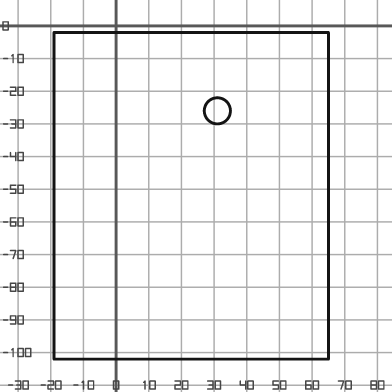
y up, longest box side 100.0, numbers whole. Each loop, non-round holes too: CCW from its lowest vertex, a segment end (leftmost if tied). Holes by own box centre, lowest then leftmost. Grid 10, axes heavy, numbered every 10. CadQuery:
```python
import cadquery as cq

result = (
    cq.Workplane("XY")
    .moveTo(-19.0, -102.0)
    .lineTo(65.0, -102.0)
    .lineTo(65.0, -2.0)
    .lineTo(-19.0, -2.0)
    .close()
    .moveTo(31.0, -26.0)
    .circle(4.0)
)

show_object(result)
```